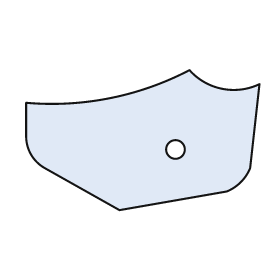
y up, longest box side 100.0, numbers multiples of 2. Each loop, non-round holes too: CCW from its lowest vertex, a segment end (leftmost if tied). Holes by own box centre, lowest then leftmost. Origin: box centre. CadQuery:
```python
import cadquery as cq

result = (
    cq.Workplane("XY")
    .moveTo(-10.0, -30.0)
    .lineTo(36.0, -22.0)
    .threePointArc((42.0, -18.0), (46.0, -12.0))
    .lineTo(50.0, 24.0)
    .threePointArc((34.0, 22.0), (20.0, 30.0))
    .threePointArc((-14.0, 18.0), (-50.0, 16.0))
    .lineTo(-50.0, 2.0)
    .threePointArc((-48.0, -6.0), (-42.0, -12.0))
    .close()
    .moveTo(14.0, -4.0)
    .circle(4.0)
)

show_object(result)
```